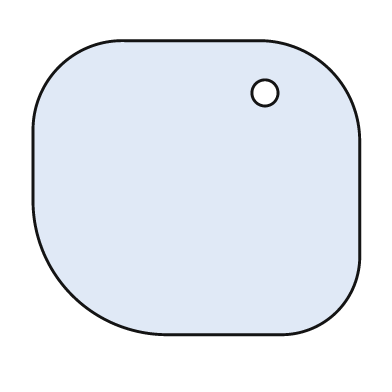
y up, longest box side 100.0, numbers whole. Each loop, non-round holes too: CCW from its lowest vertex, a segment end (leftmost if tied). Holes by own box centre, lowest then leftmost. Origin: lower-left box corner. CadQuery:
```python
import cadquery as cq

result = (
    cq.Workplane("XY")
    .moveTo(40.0, 0.0)
    .lineTo(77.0, 0.0)
    .threePointArc((93.0, 7.0), (100.0, 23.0))
    .lineTo(100.0, 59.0)
    .threePointArc((91.0, 81.0), (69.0, 90.0))
    .lineTo(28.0, 90.0)
    .threePointArc((8.0, 82.0), (0.0, 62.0))
    .lineTo(0.0, 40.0)
    .threePointArc((12.0, 12.0), (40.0, 0.0))
    .close()
    .moveTo(71.0, 74.0)
    .circle(4.0)
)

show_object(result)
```